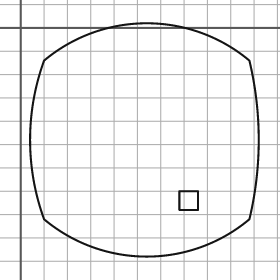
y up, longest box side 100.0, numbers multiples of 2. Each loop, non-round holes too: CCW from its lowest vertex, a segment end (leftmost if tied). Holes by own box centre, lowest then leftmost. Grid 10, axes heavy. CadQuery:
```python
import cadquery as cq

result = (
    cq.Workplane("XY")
    .moveTo(10.0, -82.0)
    .threePointArc((54.0, -98.0), (98.0, -82.0))
    .threePointArc((102.0, -48.0), (98.0, -14.0))
    .threePointArc((54.0, 2.0), (10.0, -14.0))
    .threePointArc((4.0, -48.0), (10.0, -82.0))
    .close()
    .moveTo(68.0, -78.0)
    .lineTo(76.0, -78.0)
    .lineTo(76.0, -70.0)
    .lineTo(68.0, -70.0)
    .close()
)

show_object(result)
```